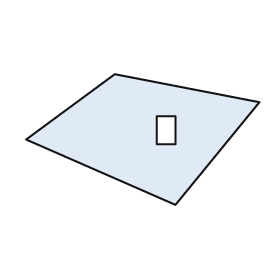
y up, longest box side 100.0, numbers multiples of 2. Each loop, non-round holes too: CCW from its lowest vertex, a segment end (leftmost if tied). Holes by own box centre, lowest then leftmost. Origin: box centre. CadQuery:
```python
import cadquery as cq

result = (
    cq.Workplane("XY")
    .moveTo(14.0, -28.0)
    .lineTo(50.0, 16.0)
    .lineTo(-12.0, 28.0)
    .lineTo(-50.0, 0.0)
    .close()
    .moveTo(6.0, -2.0)
    .lineTo(14.0, -2.0)
    .lineTo(14.0, 10.0)
    .lineTo(6.0, 10.0)
    .close()
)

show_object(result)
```